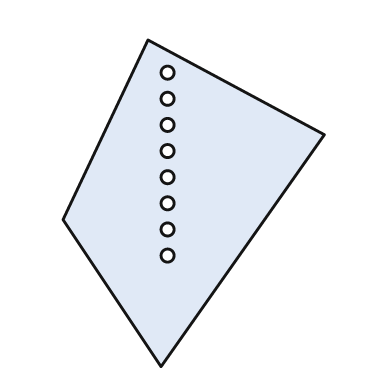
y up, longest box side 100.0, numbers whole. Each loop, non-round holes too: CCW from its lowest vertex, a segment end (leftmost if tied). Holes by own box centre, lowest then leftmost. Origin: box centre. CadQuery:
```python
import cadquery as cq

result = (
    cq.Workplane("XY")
    .moveTo(-10.0, -50.0)
    .lineTo(40.0, 21.0)
    .lineTo(-14.0, 50.0)
    .lineTo(-40.0, -5.0)
    .close()
    .moveTo(-8.0, -16.0)
    .circle(2.0)
    .moveTo(-8.0, -8.0)
    .circle(2.0)
    .moveTo(-8.0, 0.0)
    .circle(2.0)
    .moveTo(-8.0, 8.0)
    .circle(2.0)
    .moveTo(-8.0, 16.0)
    .circle(2.0)
    .moveTo(-8.0, 24.0)
    .circle(2.0)
    .moveTo(-8.0, 32.0)
    .circle(2.0)
    .moveTo(-8.0, 40.0)
    .circle(2.0)
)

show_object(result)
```